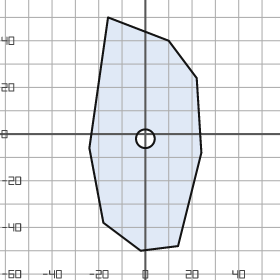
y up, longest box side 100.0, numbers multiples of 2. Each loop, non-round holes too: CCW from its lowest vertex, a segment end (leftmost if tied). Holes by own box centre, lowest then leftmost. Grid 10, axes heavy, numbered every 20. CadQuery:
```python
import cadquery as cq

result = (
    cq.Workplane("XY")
    .moveTo(-2.0, -50.0)
    .lineTo(14.0, -48.0)
    .lineTo(24.0, -8.0)
    .lineTo(22.0, 24.0)
    .lineTo(10.0, 40.0)
    .lineTo(-16.0, 50.0)
    .lineTo(-24.0, -6.0)
    .lineTo(-18.0, -38.0)
    .close()
    .moveTo(0.0, -2.0)
    .circle(4.0)
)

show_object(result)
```